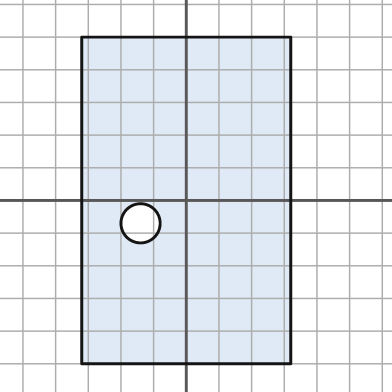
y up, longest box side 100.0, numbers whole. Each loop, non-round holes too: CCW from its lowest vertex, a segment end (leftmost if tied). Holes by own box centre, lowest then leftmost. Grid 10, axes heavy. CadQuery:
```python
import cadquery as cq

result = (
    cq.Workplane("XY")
    .moveTo(-32.0, -50.0)
    .lineTo(32.0, -50.0)
    .lineTo(32.0, 50.0)
    .lineTo(-32.0, 50.0)
    .close()
    .moveTo(-14.0, -7.0)
    .circle(6.0)
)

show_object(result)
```